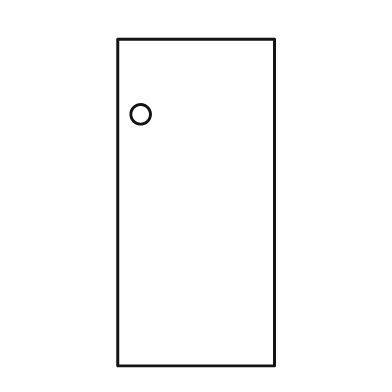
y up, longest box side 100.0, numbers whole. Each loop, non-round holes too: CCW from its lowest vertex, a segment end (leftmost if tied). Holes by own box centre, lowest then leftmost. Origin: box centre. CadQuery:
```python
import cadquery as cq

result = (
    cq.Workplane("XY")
    .moveTo(-24.0, -50.0)
    .lineTo(24.0, -50.0)
    .lineTo(24.0, 50.0)
    .lineTo(-24.0, 50.0)
    .close()
    .moveTo(-17.0, 27.0)
    .circle(3.0)
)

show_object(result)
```